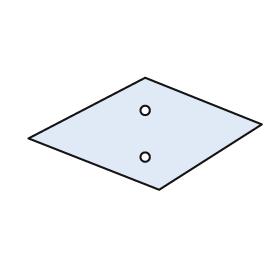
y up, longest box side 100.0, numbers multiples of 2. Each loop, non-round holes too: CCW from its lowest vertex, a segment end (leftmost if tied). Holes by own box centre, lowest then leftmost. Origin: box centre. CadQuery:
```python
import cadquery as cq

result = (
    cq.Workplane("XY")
    .moveTo(6.0, -24.0)
    .lineTo(50.0, 4.0)
    .lineTo(0.0, 24.0)
    .lineTo(-50.0, -2.0)
    .close()
    .moveTo(0.0, -10.0)
    .circle(2.0)
    .moveTo(0.0, 10.0)
    .circle(2.0)
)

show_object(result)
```